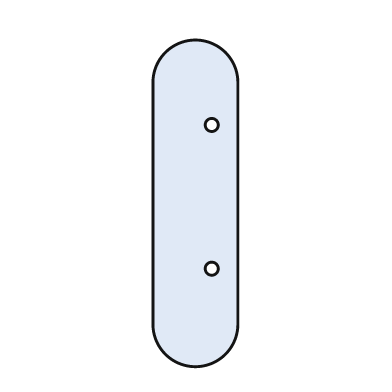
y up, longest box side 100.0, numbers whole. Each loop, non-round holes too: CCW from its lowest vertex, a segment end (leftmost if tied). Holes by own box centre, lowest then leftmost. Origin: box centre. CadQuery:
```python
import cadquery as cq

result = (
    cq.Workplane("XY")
    .moveTo(-13.0, -37.0)
    .threePointArc((0.0, -50.0), (13.0, -37.0))
    .lineTo(13.0, 37.0)
    .threePointArc((0.0, 50.0), (-13.0, 37.0))
    .close()
    .moveTo(5.0, -20.0)
    .circle(2.0)
    .moveTo(5.0, 24.0)
    .circle(2.0)
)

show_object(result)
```